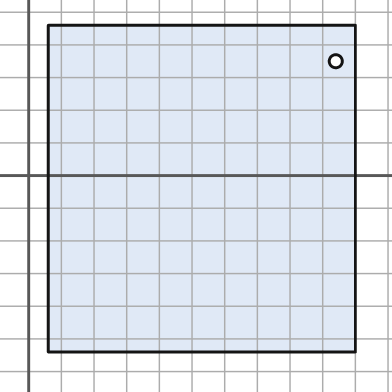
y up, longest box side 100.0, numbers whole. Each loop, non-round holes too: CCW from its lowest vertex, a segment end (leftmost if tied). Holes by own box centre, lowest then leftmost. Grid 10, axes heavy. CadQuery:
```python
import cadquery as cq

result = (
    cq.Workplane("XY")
    .moveTo(6.0, -54.0)
    .lineTo(100.0, -54.0)
    .lineTo(100.0, 46.0)
    .lineTo(6.0, 46.0)
    .close()
    .moveTo(94.0, 35.0)
    .circle(2.0)
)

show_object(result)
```